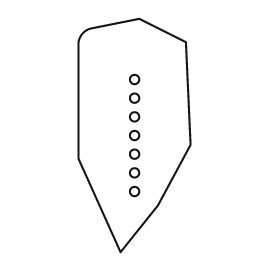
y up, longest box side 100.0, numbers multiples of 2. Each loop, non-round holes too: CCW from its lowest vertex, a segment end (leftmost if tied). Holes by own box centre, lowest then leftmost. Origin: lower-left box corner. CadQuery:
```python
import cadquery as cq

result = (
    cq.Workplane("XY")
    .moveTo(18.0, 0.0)
    .lineTo(34.0, 20.0)
    .lineTo(48.0, 46.0)
    .lineTo(46.0, 90.0)
    .lineTo(26.0, 100.0)
    .lineTo(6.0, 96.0)
    .threePointArc((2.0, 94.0), (0.0, 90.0))
    .lineTo(0.0, 40.0)
    .close()
    .moveTo(24.0, 26.0)
    .circle(2.0)
    .moveTo(24.0, 34.0)
    .circle(2.0)
    .moveTo(24.0, 42.0)
    .circle(2.0)
    .moveTo(24.0, 50.0)
    .circle(2.0)
    .moveTo(24.0, 58.0)
    .circle(2.0)
    .moveTo(24.0, 66.0)
    .circle(2.0)
    .moveTo(24.0, 74.0)
    .circle(2.0)
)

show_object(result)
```